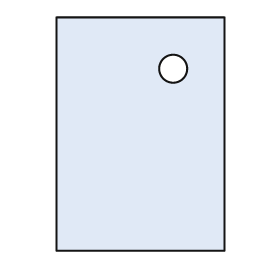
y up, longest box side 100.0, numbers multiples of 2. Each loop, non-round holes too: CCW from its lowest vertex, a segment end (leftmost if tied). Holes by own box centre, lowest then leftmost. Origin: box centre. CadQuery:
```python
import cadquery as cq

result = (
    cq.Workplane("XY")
    .moveTo(-36.0, -50.0)
    .lineTo(36.0, -50.0)
    .lineTo(36.0, 50.0)
    .lineTo(-36.0, 50.0)
    .close()
    .moveTo(14.0, 28.0)
    .circle(6.0)
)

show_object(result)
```